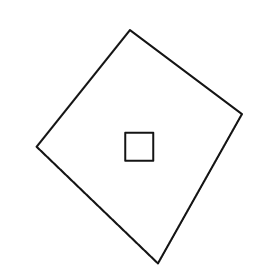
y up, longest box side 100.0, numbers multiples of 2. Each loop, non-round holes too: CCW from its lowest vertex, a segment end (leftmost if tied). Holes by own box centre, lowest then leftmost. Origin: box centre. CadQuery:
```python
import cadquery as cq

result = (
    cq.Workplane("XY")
    .moveTo(8.0, -50.0)
    .lineTo(44.0, 14.0)
    .lineTo(-4.0, 50.0)
    .lineTo(-44.0, 0.0)
    .close()
    .moveTo(-6.0, -6.0)
    .lineTo(6.0, -6.0)
    .lineTo(6.0, 6.0)
    .lineTo(-6.0, 6.0)
    .close()
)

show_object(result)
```